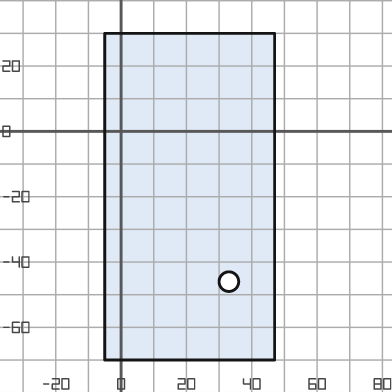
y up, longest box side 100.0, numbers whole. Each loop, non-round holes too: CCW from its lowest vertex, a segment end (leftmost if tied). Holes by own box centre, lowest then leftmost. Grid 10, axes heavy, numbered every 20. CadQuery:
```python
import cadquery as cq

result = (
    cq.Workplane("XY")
    .moveTo(-5.0, -70.0)
    .lineTo(47.0, -70.0)
    .lineTo(47.0, 30.0)
    .lineTo(-5.0, 30.0)
    .close()
    .moveTo(33.0, -46.0)
    .circle(3.0)
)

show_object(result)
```